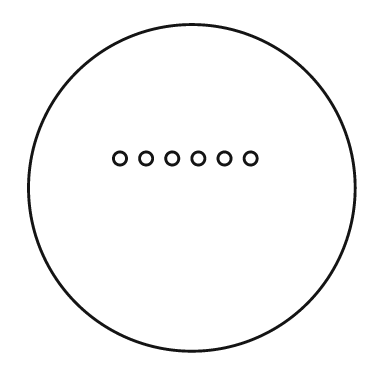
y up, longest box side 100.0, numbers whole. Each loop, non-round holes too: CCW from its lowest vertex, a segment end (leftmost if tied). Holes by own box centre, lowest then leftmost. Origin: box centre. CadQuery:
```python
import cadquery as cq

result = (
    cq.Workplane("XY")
    .moveTo(0.0, 0.0)
    .circle(50.0)
    .moveTo(-22.0, 9.0)
    .circle(2.0)
    .moveTo(-14.0, 9.0)
    .circle(2.0)
    .moveTo(-6.0, 9.0)
    .circle(2.0)
    .moveTo(2.0, 9.0)
    .circle(2.0)
    .moveTo(10.0, 9.0)
    .circle(2.0)
    .moveTo(18.0, 9.0)
    .circle(2.0)
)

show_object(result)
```